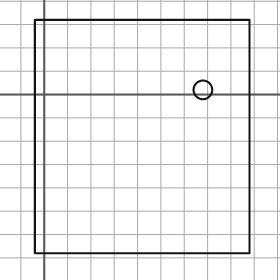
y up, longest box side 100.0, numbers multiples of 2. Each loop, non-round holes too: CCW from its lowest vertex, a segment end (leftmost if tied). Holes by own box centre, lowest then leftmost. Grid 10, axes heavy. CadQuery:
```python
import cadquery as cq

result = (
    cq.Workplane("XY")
    .moveTo(-4.0, -68.0)
    .lineTo(88.0, -68.0)
    .lineTo(88.0, 32.0)
    .lineTo(-4.0, 32.0)
    .close()
    .moveTo(68.0, 2.0)
    .circle(4.0)
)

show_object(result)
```